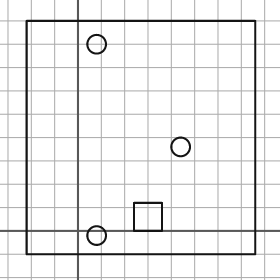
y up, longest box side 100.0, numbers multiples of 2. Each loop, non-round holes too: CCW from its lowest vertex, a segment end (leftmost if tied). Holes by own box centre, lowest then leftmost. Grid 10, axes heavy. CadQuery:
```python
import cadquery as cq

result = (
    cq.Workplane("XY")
    .moveTo(-22.0, -10.0)
    .lineTo(76.0, -10.0)
    .lineTo(76.0, 90.0)
    .lineTo(-22.0, 90.0)
    .close()
    .moveTo(8.0, -2.0)
    .circle(4.0)
    .moveTo(24.0, 0.0)
    .lineTo(36.0, 0.0)
    .lineTo(36.0, 12.0)
    .lineTo(24.0, 12.0)
    .close()
    .moveTo(44.0, 36.0)
    .circle(4.0)
    .moveTo(8.0, 80.0)
    .circle(4.0)
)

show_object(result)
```